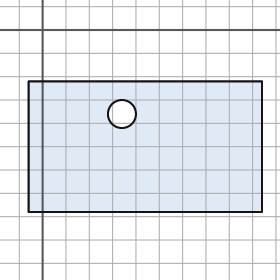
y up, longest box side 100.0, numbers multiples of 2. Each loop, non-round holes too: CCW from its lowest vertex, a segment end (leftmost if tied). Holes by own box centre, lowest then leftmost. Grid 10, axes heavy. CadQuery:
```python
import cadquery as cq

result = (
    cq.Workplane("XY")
    .moveTo(-6.0, -78.0)
    .lineTo(94.0, -78.0)
    .lineTo(94.0, -22.0)
    .lineTo(-6.0, -22.0)
    .close()
    .moveTo(34.0, -36.0)
    .circle(6.0)
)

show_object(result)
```